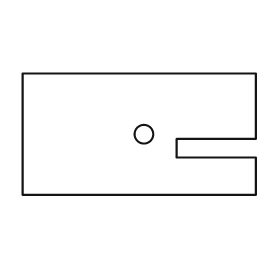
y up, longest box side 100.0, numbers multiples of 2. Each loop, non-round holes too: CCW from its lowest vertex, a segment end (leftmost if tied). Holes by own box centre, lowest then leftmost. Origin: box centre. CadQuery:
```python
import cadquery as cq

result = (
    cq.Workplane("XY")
    .moveTo(-50.0, -26.0)
    .lineTo(50.0, -26.0)
    .lineTo(50.0, -10.0)
    .lineTo(16.0, -10.0)
    .lineTo(16.0, -2.0)
    .lineTo(50.0, -2.0)
    .lineTo(50.0, 26.0)
    .lineTo(-50.0, 26.0)
    .close()
    .moveTo(2.0, 0.0)
    .circle(4.0)
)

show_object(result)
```